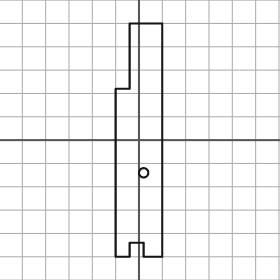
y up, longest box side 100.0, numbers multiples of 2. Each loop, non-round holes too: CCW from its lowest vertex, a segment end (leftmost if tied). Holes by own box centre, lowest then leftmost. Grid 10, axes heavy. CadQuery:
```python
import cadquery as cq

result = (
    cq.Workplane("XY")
    .moveTo(-10.0, -50.0)
    .lineTo(-4.0, -50.0)
    .lineTo(-4.0, -44.0)
    .lineTo(2.0, -44.0)
    .lineTo(2.0, -50.0)
    .lineTo(10.0, -50.0)
    .lineTo(10.0, 50.0)
    .lineTo(-4.0, 50.0)
    .lineTo(-4.0, 22.0)
    .lineTo(-10.0, 22.0)
    .close()
    .moveTo(2.0, -14.0)
    .circle(2.0)
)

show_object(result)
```